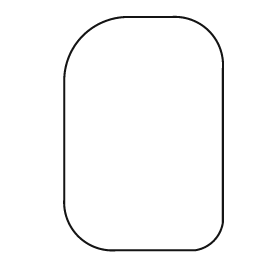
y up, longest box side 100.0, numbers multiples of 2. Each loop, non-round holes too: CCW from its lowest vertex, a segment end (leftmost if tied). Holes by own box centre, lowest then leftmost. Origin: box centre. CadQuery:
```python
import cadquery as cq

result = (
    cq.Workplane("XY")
    .moveTo(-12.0, -50.0)
    .lineTo(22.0, -50.0)
    .threePointArc((30.0, -46.0), (34.0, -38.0))
    .lineTo(34.0, 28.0)
    .threePointArc((28.0, 44.0), (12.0, 50.0))
    .lineTo(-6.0, 50.0)
    .threePointArc((-26.0, 42.0), (-34.0, 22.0))
    .lineTo(-34.0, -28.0)
    .threePointArc((-28.0, -44.0), (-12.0, -50.0))
    .close()
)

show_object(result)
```